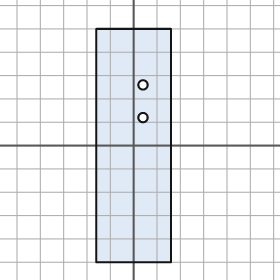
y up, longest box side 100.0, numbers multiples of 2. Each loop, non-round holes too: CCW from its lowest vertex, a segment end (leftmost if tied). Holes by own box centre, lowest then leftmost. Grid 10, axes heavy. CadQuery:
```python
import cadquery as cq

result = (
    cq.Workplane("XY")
    .moveTo(-16.0, -50.0)
    .lineTo(16.0, -50.0)
    .lineTo(16.0, 50.0)
    .lineTo(-16.0, 50.0)
    .close()
    .moveTo(4.0, 12.0)
    .circle(2.0)
    .moveTo(4.0, 26.0)
    .circle(2.0)
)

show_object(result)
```